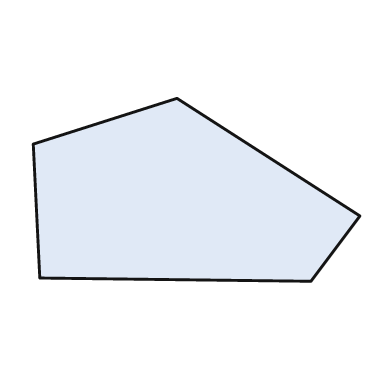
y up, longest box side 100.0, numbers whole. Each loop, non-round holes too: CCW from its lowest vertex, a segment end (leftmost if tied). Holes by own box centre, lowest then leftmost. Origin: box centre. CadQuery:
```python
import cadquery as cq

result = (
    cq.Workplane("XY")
    .moveTo(35.0, -28.0)
    .lineTo(50.0, -8.0)
    .lineTo(-6.0, 28.0)
    .lineTo(-50.0, 14.0)
    .lineTo(-48.0, -27.0)
    .close()
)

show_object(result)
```